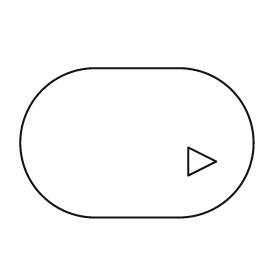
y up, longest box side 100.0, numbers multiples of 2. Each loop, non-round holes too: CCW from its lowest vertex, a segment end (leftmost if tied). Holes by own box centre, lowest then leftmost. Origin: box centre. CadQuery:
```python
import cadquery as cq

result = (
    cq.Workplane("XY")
    .moveTo(-18.0, -32.0)
    .lineTo(18.0, -32.0)
    .threePointArc((50.0, 0.0), (18.0, 32.0))
    .lineTo(-18.0, 32.0)
    .threePointArc((-50.0, 0.0), (-18.0, -32.0))
    .close()
    .moveTo(22.0, -14.0)
    .lineTo(34.0, -8.0)
    .lineTo(22.0, -2.0)
    .close()
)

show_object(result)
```